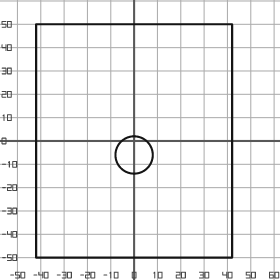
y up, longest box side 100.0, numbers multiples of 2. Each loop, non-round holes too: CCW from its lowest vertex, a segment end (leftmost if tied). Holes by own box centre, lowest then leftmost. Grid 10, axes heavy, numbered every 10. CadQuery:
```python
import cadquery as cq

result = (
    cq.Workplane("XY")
    .moveTo(-42.0, -50.0)
    .lineTo(42.0, -50.0)
    .lineTo(42.0, 50.0)
    .lineTo(-42.0, 50.0)
    .close()
    .moveTo(0.0, -6.0)
    .circle(8.0)
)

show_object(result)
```